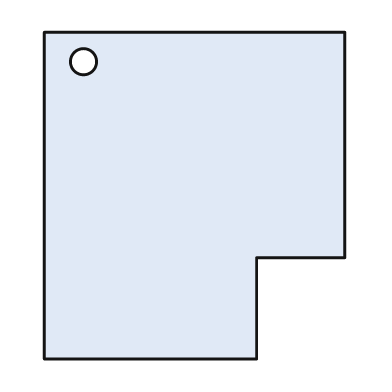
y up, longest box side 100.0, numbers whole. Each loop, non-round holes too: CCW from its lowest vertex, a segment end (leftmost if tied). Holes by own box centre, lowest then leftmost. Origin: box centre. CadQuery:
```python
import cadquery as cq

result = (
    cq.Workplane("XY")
    .moveTo(-46.0, -50.0)
    .lineTo(19.0, -50.0)
    .lineTo(19.0, -19.0)
    .lineTo(46.0, -19.0)
    .lineTo(46.0, 50.0)
    .lineTo(-46.0, 50.0)
    .close()
    .moveTo(-34.0, 41.0)
    .circle(4.0)
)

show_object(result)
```